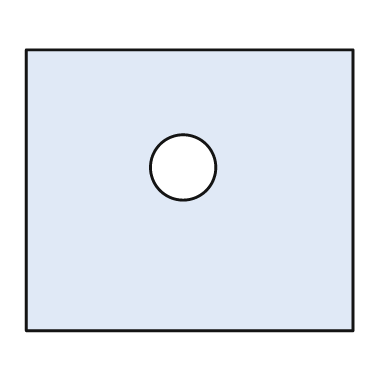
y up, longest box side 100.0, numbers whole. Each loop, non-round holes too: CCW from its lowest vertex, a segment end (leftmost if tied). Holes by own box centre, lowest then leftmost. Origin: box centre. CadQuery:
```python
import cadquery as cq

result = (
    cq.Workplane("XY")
    .moveTo(-50.0, -43.0)
    .lineTo(50.0, -43.0)
    .lineTo(50.0, 43.0)
    .lineTo(-50.0, 43.0)
    .close()
    .moveTo(-2.0, 7.0)
    .circle(10.0)
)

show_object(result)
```